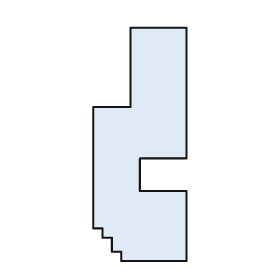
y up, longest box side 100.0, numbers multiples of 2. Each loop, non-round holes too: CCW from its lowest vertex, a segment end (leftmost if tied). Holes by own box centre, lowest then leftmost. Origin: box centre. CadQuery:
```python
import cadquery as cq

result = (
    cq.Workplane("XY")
    .moveTo(-8.0, -50.0)
    .lineTo(20.0, -50.0)
    .lineTo(20.0, -20.0)
    .lineTo(0.0, -20.0)
    .lineTo(0.0, -6.0)
    .lineTo(20.0, -6.0)
    .lineTo(20.0, 50.0)
    .lineTo(-4.0, 50.0)
    .lineTo(-4.0, 16.0)
    .lineTo(-20.0, 16.0)
    .lineTo(-20.0, -36.0)
    .lineTo(-16.0, -36.0)
    .lineTo(-16.0, -40.0)
    .lineTo(-12.0, -40.0)
    .lineTo(-12.0, -46.0)
    .lineTo(-8.0, -46.0)
    .close()
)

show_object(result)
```